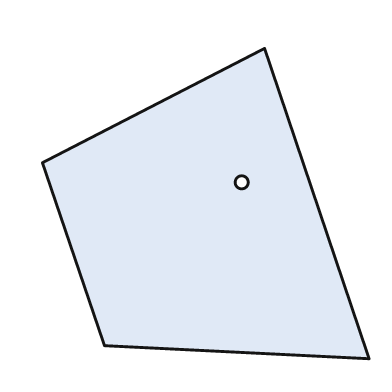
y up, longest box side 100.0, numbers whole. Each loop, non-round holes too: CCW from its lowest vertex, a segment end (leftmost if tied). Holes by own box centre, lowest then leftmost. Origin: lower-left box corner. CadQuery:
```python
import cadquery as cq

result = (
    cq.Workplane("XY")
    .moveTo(100.0, 0.0)
    .lineTo(68.0, 95.0)
    .lineTo(0.0, 60.0)
    .lineTo(19.0, 4.0)
    .close()
    .moveTo(61.0, 54.0)
    .circle(2.0)
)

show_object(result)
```